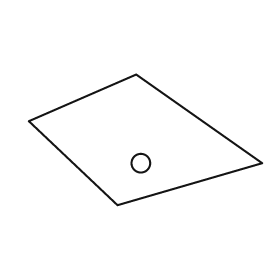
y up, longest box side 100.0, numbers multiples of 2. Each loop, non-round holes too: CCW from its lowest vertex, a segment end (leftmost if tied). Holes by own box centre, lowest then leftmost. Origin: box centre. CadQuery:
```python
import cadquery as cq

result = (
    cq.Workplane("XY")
    .moveTo(-12.0, -28.0)
    .lineTo(50.0, -10.0)
    .lineTo(-4.0, 28.0)
    .lineTo(-50.0, 8.0)
    .close()
    .moveTo(-2.0, -10.0)
    .circle(4.0)
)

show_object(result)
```